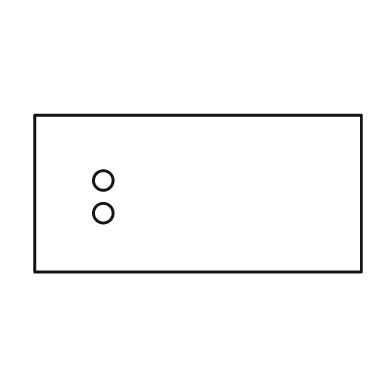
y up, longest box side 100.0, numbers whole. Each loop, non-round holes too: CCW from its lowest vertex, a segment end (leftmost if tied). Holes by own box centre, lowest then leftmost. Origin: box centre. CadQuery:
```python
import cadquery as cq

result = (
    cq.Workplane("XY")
    .moveTo(-50.0, -24.0)
    .lineTo(50.0, -24.0)
    .lineTo(50.0, 24.0)
    .lineTo(-50.0, 24.0)
    .close()
    .moveTo(-29.0, -6.0)
    .circle(3.0)
    .moveTo(-29.0, 4.0)
    .circle(3.0)
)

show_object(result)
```